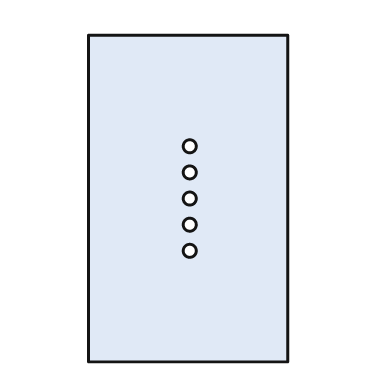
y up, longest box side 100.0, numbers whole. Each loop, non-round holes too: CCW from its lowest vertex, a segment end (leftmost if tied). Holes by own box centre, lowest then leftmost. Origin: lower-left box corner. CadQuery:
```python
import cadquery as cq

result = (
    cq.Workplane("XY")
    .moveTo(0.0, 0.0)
    .lineTo(61.0, 0.0)
    .lineTo(61.0, 100.0)
    .lineTo(0.0, 100.0)
    .close()
    .moveTo(31.0, 34.0)
    .circle(2.0)
    .moveTo(31.0, 42.0)
    .circle(2.0)
    .moveTo(31.0, 50.0)
    .circle(2.0)
    .moveTo(31.0, 58.0)
    .circle(2.0)
    .moveTo(31.0, 66.0)
    .circle(2.0)
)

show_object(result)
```